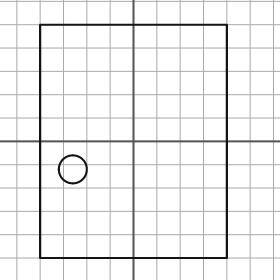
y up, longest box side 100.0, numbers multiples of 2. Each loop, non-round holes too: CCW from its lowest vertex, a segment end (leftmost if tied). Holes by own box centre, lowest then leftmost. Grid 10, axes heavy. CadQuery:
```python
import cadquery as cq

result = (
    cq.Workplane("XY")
    .moveTo(-40.0, -50.0)
    .lineTo(40.0, -50.0)
    .lineTo(40.0, 50.0)
    .lineTo(-40.0, 50.0)
    .close()
    .moveTo(-26.0, -12.0)
    .circle(6.0)
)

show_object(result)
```